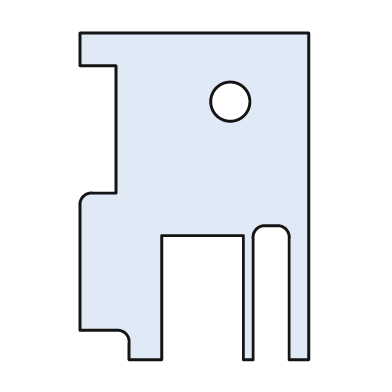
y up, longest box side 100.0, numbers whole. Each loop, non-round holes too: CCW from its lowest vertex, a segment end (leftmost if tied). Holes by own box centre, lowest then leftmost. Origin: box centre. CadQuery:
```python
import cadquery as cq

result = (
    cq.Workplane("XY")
    .moveTo(-20.0, -50.0)
    .lineTo(-10.0, -50.0)
    .lineTo(-10.0, -12.0)
    .lineTo(15.0, -12.0)
    .lineTo(15.0, -50.0)
    .lineTo(18.0, -50.0)
    .lineTo(18.0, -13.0)
    .threePointArc((19.0, -10.0), (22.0, -9.0))
    .lineTo(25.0, -9.0)
    .threePointArc((28.0, -10.0), (29.0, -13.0))
    .lineTo(29.0, -50.0)
    .lineTo(35.0, -50.0)
    .lineTo(35.0, 50.0)
    .lineTo(-35.0, 50.0)
    .lineTo(-35.0, 40.0)
    .lineTo(-24.0, 40.0)
    .lineTo(-24.0, 1.0)
    .lineTo(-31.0, 1.0)
    .threePointArc((-34.0, 0.0), (-35.0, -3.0))
    .lineTo(-35.0, -41.0)
    .lineTo(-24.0, -41.0)
    .threePointArc((-21.0, -42.0), (-20.0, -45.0))
    .close()
    .moveTo(11.0, 29.0)
    .circle(6.0)
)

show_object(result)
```